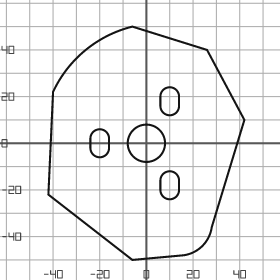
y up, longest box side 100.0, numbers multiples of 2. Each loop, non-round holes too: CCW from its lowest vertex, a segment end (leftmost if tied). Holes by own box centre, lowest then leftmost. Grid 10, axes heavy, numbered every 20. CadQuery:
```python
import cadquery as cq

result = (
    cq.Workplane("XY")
    .moveTo(-6.0, -50.0)
    .lineTo(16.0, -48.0)
    .threePointArc((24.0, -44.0), (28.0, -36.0))
    .lineTo(42.0, 10.0)
    .lineTo(26.0, 40.0)
    .lineTo(-6.0, 50.0)
    .threePointArc((-26.0, 40.0), (-40.0, 22.0))
    .lineTo(-42.0, -22.0)
    .close()
    .moveTo(6.0, -20.0)
    .threePointArc((10.0, -24.0), (14.0, -20.0))
    .lineTo(14.0, -16.0)
    .threePointArc((10.0, -12.0), (6.0, -16.0))
    .close()
    .moveTo(-24.0, -2.0)
    .threePointArc((-20.0, -6.0), (-16.0, -2.0))
    .lineTo(-16.0, 2.0)
    .threePointArc((-20.0, 6.0), (-24.0, 2.0))
    .close()
    .moveTo(0.0, 0.0)
    .circle(8.0)
    .moveTo(6.0, 16.0)
    .threePointArc((10.0, 12.0), (14.0, 16.0))
    .lineTo(14.0, 20.0)
    .threePointArc((10.0, 24.0), (6.0, 20.0))
    .close()
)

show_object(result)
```